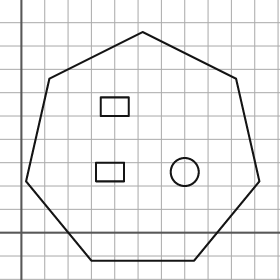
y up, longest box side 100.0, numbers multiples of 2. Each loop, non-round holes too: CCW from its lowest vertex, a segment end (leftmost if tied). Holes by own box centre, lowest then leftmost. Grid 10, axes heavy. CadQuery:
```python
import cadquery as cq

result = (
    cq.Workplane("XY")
    .moveTo(30.0, -12.0)
    .lineTo(74.0, -12.0)
    .lineTo(102.0, 22.0)
    .lineTo(92.0, 66.0)
    .lineTo(52.0, 86.0)
    .lineTo(12.0, 66.0)
    .lineTo(2.0, 22.0)
    .close()
    .moveTo(32.0, 22.0)
    .lineTo(44.0, 22.0)
    .lineTo(44.0, 30.0)
    .lineTo(32.0, 30.0)
    .close()
    .moveTo(70.0, 26.0)
    .circle(6.0)
    .moveTo(34.0, 50.0)
    .lineTo(46.0, 50.0)
    .lineTo(46.0, 58.0)
    .lineTo(34.0, 58.0)
    .close()
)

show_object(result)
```